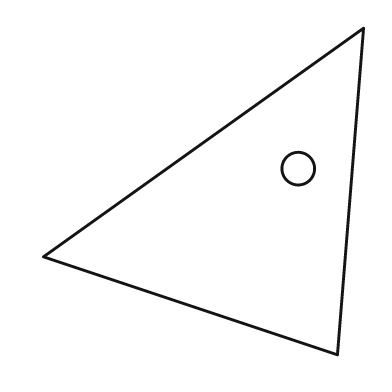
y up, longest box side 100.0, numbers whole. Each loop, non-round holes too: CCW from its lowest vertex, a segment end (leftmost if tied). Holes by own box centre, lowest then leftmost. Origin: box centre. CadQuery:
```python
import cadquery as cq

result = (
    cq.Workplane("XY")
    .moveTo(41.0, -50.0)
    .lineTo(49.0, 50.0)
    .lineTo(-49.0, -20.0)
    .close()
    .moveTo(29.0, 7.0)
    .circle(5.0)
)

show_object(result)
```